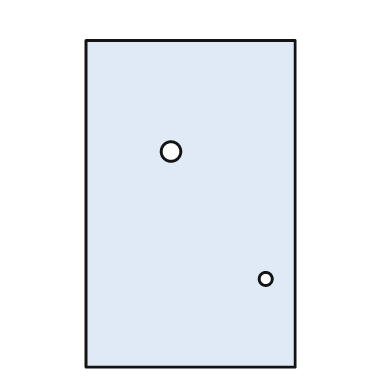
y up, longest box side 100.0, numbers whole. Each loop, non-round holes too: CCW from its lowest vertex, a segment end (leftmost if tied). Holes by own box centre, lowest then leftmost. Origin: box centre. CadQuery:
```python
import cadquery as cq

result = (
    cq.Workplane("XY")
    .moveTo(-32.0, -50.0)
    .lineTo(32.0, -50.0)
    .lineTo(32.0, 50.0)
    .lineTo(-32.0, 50.0)
    .close()
    .moveTo(23.0, -23.0)
    .circle(2.0)
    .moveTo(-6.0, 16.0)
    .circle(3.0)
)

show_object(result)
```